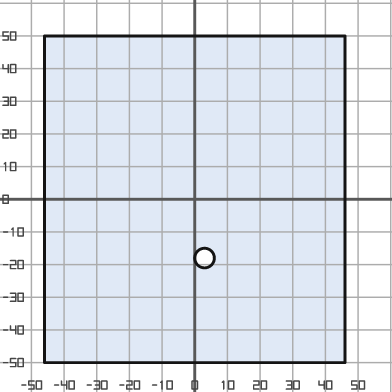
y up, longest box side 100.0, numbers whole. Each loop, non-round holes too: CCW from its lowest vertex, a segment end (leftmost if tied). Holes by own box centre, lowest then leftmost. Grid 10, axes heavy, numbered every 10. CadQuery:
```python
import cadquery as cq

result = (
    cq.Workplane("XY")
    .moveTo(-46.0, -50.0)
    .lineTo(46.0, -50.0)
    .lineTo(46.0, 50.0)
    .lineTo(-46.0, 50.0)
    .close()
    .moveTo(3.0, -18.0)
    .circle(3.0)
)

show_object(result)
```